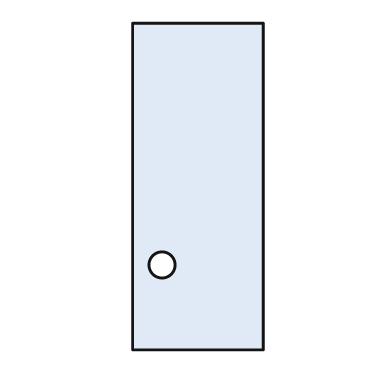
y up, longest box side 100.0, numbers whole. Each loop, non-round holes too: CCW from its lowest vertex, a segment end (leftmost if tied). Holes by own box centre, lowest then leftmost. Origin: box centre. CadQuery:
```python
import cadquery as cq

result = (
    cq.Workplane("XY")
    .moveTo(-20.0, -50.0)
    .lineTo(20.0, -50.0)
    .lineTo(20.0, 50.0)
    .lineTo(-20.0, 50.0)
    .close()
    .moveTo(-11.0, -24.0)
    .circle(4.0)
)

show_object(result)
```